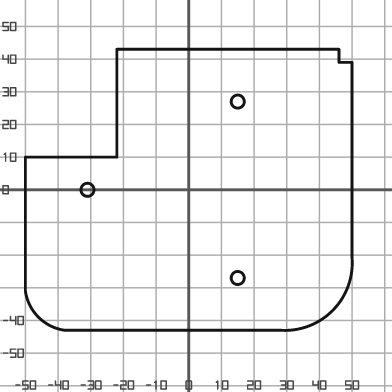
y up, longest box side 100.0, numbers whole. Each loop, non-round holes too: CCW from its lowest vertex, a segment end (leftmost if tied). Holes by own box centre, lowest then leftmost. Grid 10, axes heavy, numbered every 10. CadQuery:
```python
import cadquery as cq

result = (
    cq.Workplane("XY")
    .moveTo(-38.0, -43.0)
    .lineTo(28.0, -43.0)
    .threePointArc((44.0, -37.0), (50.0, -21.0))
    .lineTo(50.0, 39.0)
    .lineTo(46.0, 39.0)
    .lineTo(46.0, 43.0)
    .lineTo(-22.0, 43.0)
    .lineTo(-22.0, 10.0)
    .lineTo(-50.0, 10.0)
    .lineTo(-50.0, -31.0)
    .threePointArc((-46.0, -39.0), (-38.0, -43.0))
    .close()
    .moveTo(15.0, -27.0)
    .circle(2.0)
    .moveTo(-31.0, 0.0)
    .circle(2.0)
    .moveTo(15.0, 27.0)
    .circle(2.0)
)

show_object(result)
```